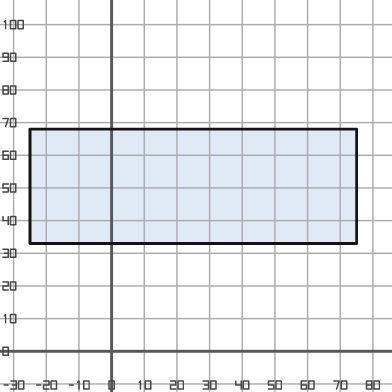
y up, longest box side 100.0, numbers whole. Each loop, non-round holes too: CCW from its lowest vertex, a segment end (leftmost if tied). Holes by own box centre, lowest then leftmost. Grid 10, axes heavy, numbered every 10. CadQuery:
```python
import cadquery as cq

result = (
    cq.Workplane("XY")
    .moveTo(-25.0, 33.0)
    .lineTo(75.0, 33.0)
    .lineTo(75.0, 68.0)
    .lineTo(-25.0, 68.0)
    .close()
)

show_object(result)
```